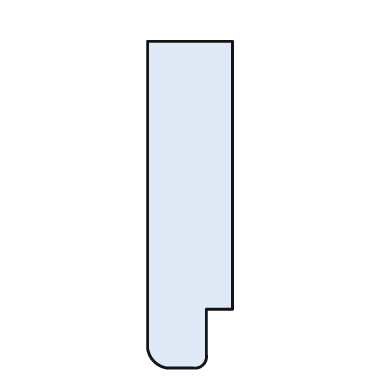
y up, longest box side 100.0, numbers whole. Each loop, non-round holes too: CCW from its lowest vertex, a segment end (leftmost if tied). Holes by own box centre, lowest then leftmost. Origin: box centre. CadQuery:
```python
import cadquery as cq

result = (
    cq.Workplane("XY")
    .moveTo(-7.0, -50.0)
    .lineTo(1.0, -50.0)
    .threePointArc((4.0, -49.0), (5.0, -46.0))
    .lineTo(5.0, -32.0)
    .lineTo(13.0, -32.0)
    .lineTo(13.0, 50.0)
    .lineTo(-13.0, 50.0)
    .lineTo(-13.0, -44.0)
    .threePointArc((-11.0, -48.0), (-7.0, -50.0))
    .close()
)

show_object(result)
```